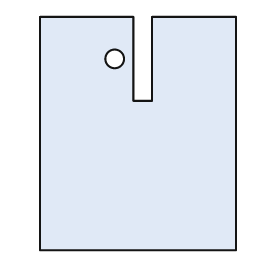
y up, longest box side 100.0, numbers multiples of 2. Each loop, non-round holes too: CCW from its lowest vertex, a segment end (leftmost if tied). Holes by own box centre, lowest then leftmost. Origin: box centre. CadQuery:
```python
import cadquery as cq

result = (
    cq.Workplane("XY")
    .moveTo(-42.0, -50.0)
    .lineTo(42.0, -50.0)
    .lineTo(42.0, 50.0)
    .lineTo(6.0, 50.0)
    .lineTo(6.0, 14.0)
    .lineTo(-2.0, 14.0)
    .lineTo(-2.0, 50.0)
    .lineTo(-42.0, 50.0)
    .close()
    .moveTo(-10.0, 32.0)
    .circle(4.0)
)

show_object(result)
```